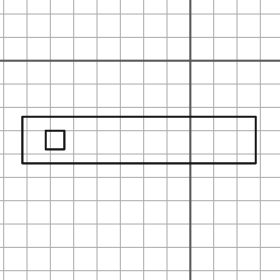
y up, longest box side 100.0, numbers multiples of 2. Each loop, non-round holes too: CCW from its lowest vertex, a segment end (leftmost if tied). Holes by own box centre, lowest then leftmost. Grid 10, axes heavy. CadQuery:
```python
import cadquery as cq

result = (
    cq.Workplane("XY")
    .moveTo(-72.0, -44.0)
    .lineTo(28.0, -44.0)
    .lineTo(28.0, -24.0)
    .lineTo(-72.0, -24.0)
    .close()
    .moveTo(-62.0, -38.0)
    .lineTo(-54.0, -38.0)
    .lineTo(-54.0, -30.0)
    .lineTo(-62.0, -30.0)
    .close()
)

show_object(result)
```